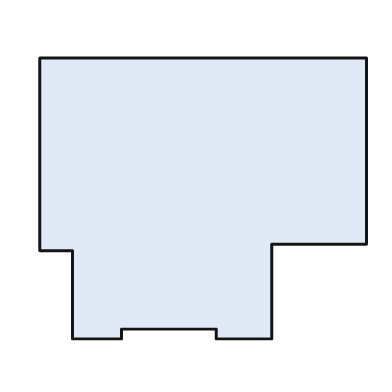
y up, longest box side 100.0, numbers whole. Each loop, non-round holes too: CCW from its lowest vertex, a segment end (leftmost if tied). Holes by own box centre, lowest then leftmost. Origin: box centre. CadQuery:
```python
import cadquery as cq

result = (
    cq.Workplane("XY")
    .moveTo(-40.0, -43.0)
    .lineTo(-25.0, -43.0)
    .lineTo(-25.0, -40.0)
    .lineTo(4.0, -40.0)
    .lineTo(4.0, -43.0)
    .lineTo(21.0, -43.0)
    .lineTo(21.0, -14.0)
    .lineTo(50.0, -14.0)
    .lineTo(50.0, 43.0)
    .lineTo(-50.0, 43.0)
    .lineTo(-50.0, -16.0)
    .lineTo(-40.0, -16.0)
    .close()
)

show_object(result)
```